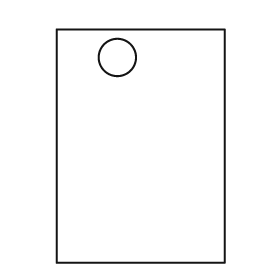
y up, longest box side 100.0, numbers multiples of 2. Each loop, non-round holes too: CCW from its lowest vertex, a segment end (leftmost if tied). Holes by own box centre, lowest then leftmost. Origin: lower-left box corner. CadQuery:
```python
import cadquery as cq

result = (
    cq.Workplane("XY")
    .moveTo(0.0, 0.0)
    .lineTo(72.0, 0.0)
    .lineTo(72.0, 100.0)
    .lineTo(0.0, 100.0)
    .close()
    .moveTo(26.0, 88.0)
    .circle(8.0)
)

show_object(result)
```